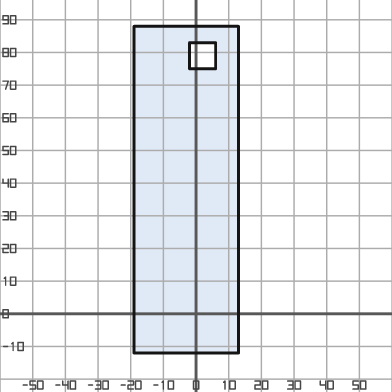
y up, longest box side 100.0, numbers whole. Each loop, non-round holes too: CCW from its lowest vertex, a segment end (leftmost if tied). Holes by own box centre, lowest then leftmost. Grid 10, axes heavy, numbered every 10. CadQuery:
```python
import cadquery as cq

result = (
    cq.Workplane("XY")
    .moveTo(-19.0, -12.0)
    .lineTo(13.0, -12.0)
    .lineTo(13.0, 88.0)
    .lineTo(-19.0, 88.0)
    .close()
    .moveTo(-2.0, 75.0)
    .lineTo(6.0, 75.0)
    .lineTo(6.0, 83.0)
    .lineTo(-2.0, 83.0)
    .close()
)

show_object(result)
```